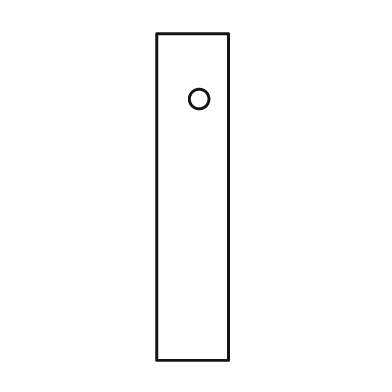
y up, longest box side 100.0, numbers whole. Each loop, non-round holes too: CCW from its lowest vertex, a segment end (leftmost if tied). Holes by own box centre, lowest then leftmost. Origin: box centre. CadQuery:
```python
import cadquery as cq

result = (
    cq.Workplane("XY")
    .moveTo(-11.0, -50.0)
    .lineTo(11.0, -50.0)
    .lineTo(11.0, 50.0)
    .lineTo(-11.0, 50.0)
    .close()
    .moveTo(2.0, 30.0)
    .circle(3.0)
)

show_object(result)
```